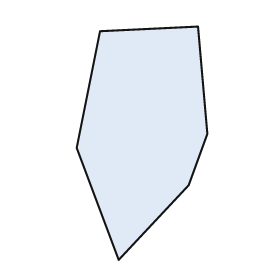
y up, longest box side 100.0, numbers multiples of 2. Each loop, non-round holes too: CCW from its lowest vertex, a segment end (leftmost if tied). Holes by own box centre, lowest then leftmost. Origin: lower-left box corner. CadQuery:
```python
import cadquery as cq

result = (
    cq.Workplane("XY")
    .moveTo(18.0, 0.0)
    .lineTo(48.0, 32.0)
    .lineTo(56.0, 54.0)
    .lineTo(52.0, 100.0)
    .lineTo(10.0, 98.0)
    .lineTo(0.0, 48.0)
    .close()
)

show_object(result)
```